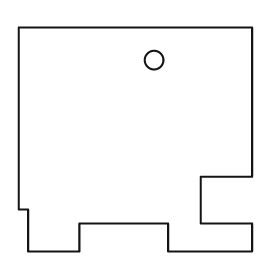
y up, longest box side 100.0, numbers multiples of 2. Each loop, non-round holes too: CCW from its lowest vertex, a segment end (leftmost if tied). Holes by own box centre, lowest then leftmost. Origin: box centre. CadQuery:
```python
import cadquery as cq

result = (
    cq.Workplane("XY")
    .moveTo(-46.0, -48.0)
    .lineTo(-24.0, -48.0)
    .lineTo(-24.0, -36.0)
    .lineTo(14.0, -36.0)
    .lineTo(14.0, -48.0)
    .lineTo(50.0, -48.0)
    .lineTo(50.0, -36.0)
    .lineTo(28.0, -36.0)
    .lineTo(28.0, -16.0)
    .lineTo(50.0, -16.0)
    .lineTo(50.0, 48.0)
    .lineTo(-50.0, 48.0)
    .lineTo(-50.0, -30.0)
    .lineTo(-46.0, -30.0)
    .close()
    .moveTo(8.0, 34.0)
    .circle(4.0)
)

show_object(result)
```